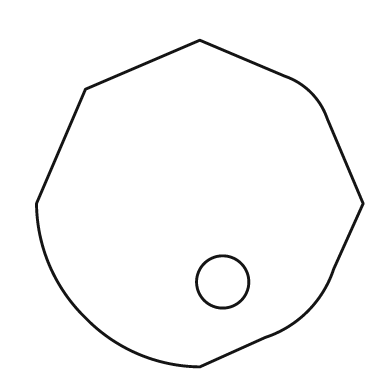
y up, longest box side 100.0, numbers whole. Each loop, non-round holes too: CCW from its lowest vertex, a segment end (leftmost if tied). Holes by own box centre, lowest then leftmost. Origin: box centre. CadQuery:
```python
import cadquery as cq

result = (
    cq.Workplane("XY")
    .moveTo(0.0, -50.0)
    .lineTo(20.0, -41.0)
    .threePointArc((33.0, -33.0), (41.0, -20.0))
    .lineTo(50.0, 0.0)
    .lineTo(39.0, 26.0)
    .threePointArc((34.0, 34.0), (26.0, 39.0))
    .lineTo(0.0, 50.0)
    .lineTo(-35.0, 35.0)
    .lineTo(-50.0, 0.0)
    .threePointArc((-46.0, -19.0), (-35.0, -35.0))
    .threePointArc((-19.0, -46.0), (0.0, -50.0))
    .close()
    .moveTo(7.0, -24.0)
    .circle(8.0)
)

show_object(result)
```